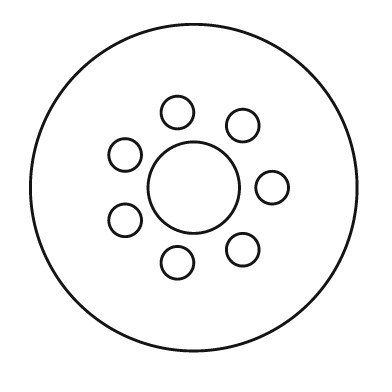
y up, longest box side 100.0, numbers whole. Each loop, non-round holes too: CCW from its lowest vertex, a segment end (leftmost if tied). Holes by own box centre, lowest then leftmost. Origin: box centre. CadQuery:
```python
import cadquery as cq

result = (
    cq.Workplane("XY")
    .moveTo(0.0, 0.0)
    .circle(50.0)
    .moveTo(-5.0, -23.0)
    .circle(5.0)
    .moveTo(15.0, -19.0)
    .circle(5.0)
    .moveTo(-21.0, -10.0)
    .circle(5.0)
    .moveTo(0.0, 0.0)
    .circle(14.0)
    .moveTo(24.0, 0.0)
    .circle(5.0)
    .moveTo(-21.0, 10.0)
    .circle(5.0)
    .moveTo(15.0, 19.0)
    .circle(5.0)
    .moveTo(-5.0, 23.0)
    .circle(5.0)
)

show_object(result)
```